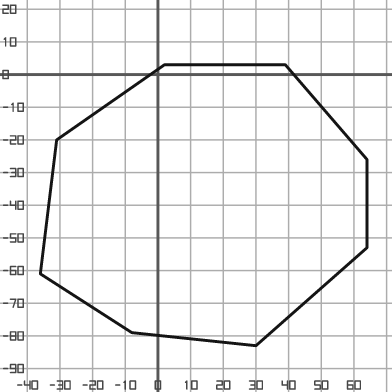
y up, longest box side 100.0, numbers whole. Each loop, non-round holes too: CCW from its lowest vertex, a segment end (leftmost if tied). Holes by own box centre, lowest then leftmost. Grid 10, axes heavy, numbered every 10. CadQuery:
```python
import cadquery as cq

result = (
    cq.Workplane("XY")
    .moveTo(30.0, -83.0)
    .lineTo(64.0, -53.0)
    .lineTo(64.0, -26.0)
    .lineTo(39.0, 3.0)
    .lineTo(2.0, 3.0)
    .lineTo(-31.0, -20.0)
    .lineTo(-36.0, -61.0)
    .lineTo(-8.0, -79.0)
    .close()
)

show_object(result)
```